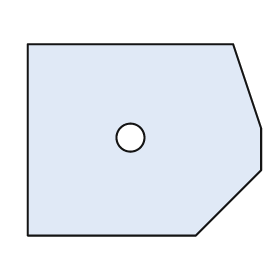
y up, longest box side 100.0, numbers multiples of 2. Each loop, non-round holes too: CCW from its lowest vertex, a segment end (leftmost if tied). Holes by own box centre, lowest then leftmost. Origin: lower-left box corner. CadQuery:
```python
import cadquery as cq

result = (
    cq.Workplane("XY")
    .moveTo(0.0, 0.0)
    .lineTo(72.0, 0.0)
    .lineTo(100.0, 28.0)
    .lineTo(100.0, 46.0)
    .lineTo(88.0, 82.0)
    .lineTo(0.0, 82.0)
    .close()
    .moveTo(44.0, 42.0)
    .circle(6.0)
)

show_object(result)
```